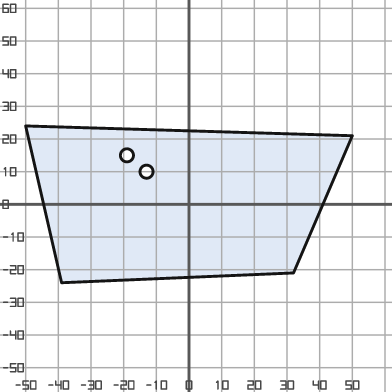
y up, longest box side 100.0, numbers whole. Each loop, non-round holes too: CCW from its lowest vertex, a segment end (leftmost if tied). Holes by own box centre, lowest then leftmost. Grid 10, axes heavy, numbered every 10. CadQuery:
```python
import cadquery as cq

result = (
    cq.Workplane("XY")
    .moveTo(-39.0, -24.0)
    .lineTo(32.0, -21.0)
    .lineTo(50.0, 21.0)
    .lineTo(-50.0, 24.0)
    .close()
    .moveTo(-13.0, 10.0)
    .circle(2.0)
    .moveTo(-19.0, 15.0)
    .circle(2.0)
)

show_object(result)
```